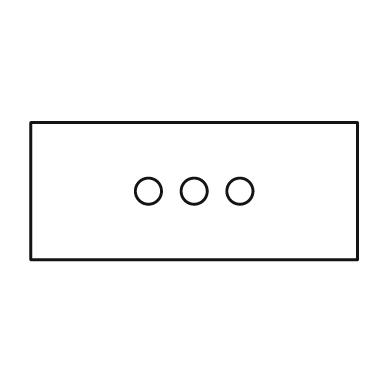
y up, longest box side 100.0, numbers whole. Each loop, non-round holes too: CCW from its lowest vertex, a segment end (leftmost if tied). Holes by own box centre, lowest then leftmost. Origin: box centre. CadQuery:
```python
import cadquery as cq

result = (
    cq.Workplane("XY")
    .moveTo(-50.0, -21.0)
    .lineTo(50.0, -21.0)
    .lineTo(50.0, 21.0)
    .lineTo(-50.0, 21.0)
    .close()
    .moveTo(-14.0, 0.0)
    .circle(4.0)
    .moveTo(0.0, 0.0)
    .circle(4.0)
    .moveTo(14.0, 0.0)
    .circle(4.0)
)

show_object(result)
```